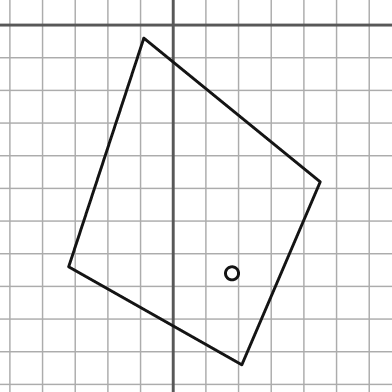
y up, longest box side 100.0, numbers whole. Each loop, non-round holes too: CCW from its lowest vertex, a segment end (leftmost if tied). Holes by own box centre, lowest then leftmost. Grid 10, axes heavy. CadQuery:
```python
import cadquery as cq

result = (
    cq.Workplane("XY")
    .moveTo(21.0, -104.0)
    .lineTo(45.0, -48.0)
    .lineTo(-9.0, -4.0)
    .lineTo(-32.0, -74.0)
    .close()
    .moveTo(18.0, -76.0)
    .circle(2.0)
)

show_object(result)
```